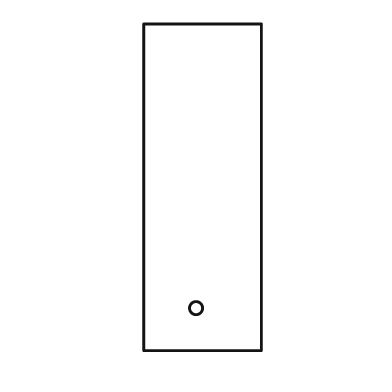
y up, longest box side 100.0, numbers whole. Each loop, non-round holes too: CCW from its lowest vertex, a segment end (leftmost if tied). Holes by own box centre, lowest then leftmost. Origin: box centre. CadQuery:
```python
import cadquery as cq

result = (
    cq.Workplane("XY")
    .moveTo(-18.0, -50.0)
    .lineTo(18.0, -50.0)
    .lineTo(18.0, 50.0)
    .lineTo(-18.0, 50.0)
    .close()
    .moveTo(-2.0, -37.0)
    .circle(2.0)
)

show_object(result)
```